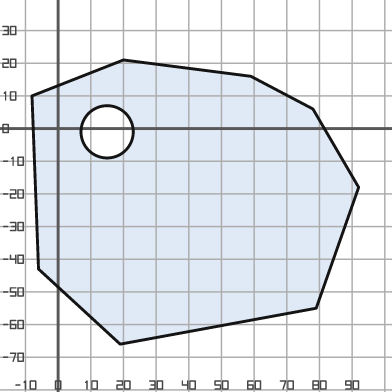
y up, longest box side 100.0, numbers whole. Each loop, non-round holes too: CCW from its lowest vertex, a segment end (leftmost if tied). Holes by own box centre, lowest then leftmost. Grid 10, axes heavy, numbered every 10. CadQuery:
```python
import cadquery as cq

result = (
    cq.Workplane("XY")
    .moveTo(19.0, -66.0)
    .lineTo(79.0, -55.0)
    .lineTo(92.0, -18.0)
    .lineTo(78.0, 6.0)
    .lineTo(59.0, 16.0)
    .lineTo(20.0, 21.0)
    .lineTo(-8.0, 10.0)
    .lineTo(-6.0, -43.0)
    .close()
    .moveTo(15.0, -1.0)
    .circle(8.0)
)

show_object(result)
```